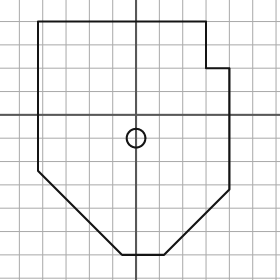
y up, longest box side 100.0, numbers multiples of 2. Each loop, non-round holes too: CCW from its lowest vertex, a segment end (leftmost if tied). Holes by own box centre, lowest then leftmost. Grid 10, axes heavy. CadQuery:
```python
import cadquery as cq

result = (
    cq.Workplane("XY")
    .moveTo(-6.0, -60.0)
    .lineTo(12.0, -60.0)
    .lineTo(40.0, -32.0)
    .lineTo(40.0, 20.0)
    .lineTo(30.0, 20.0)
    .lineTo(30.0, 40.0)
    .lineTo(-42.0, 40.0)
    .lineTo(-42.0, -24.0)
    .close()
    .moveTo(0.0, -10.0)
    .circle(4.0)
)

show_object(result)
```